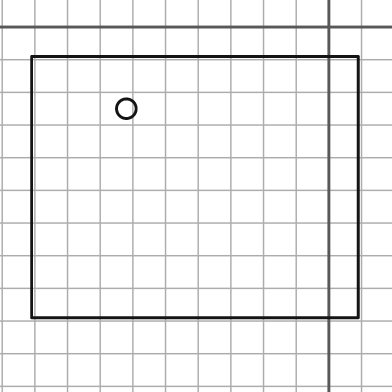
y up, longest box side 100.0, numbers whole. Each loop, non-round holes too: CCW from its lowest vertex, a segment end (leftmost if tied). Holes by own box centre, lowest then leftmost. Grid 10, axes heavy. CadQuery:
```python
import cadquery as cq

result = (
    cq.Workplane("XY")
    .moveTo(-91.0, -89.0)
    .lineTo(9.0, -89.0)
    .lineTo(9.0, -9.0)
    .lineTo(-91.0, -9.0)
    .close()
    .moveTo(-62.0, -25.0)
    .circle(3.0)
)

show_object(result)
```